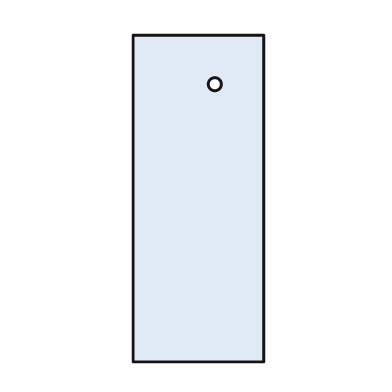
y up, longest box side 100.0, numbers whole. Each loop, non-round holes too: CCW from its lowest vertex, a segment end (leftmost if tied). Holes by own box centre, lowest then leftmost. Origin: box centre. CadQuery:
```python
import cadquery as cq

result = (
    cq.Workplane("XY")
    .moveTo(-20.0, -50.0)
    .lineTo(20.0, -50.0)
    .lineTo(20.0, 50.0)
    .lineTo(-20.0, 50.0)
    .close()
    .moveTo(5.0, 35.0)
    .circle(2.0)
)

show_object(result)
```